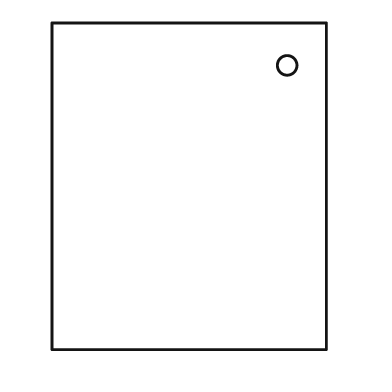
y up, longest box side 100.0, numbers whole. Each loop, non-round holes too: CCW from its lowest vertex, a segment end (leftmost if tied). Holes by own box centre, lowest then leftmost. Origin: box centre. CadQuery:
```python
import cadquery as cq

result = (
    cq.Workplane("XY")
    .moveTo(-42.0, -50.0)
    .lineTo(42.0, -50.0)
    .lineTo(42.0, 50.0)
    .lineTo(-42.0, 50.0)
    .close()
    .moveTo(30.0, 37.0)
    .circle(3.0)
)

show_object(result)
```